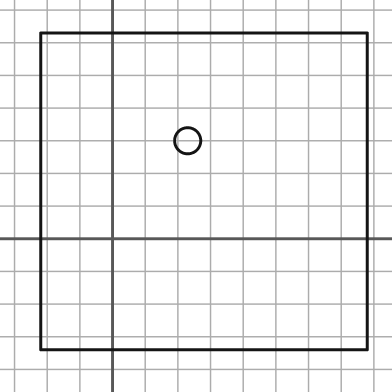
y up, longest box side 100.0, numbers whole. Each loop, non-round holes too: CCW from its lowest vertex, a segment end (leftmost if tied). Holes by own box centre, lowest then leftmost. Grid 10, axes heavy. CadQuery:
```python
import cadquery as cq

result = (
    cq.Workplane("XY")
    .moveTo(-22.0, -34.0)
    .lineTo(78.0, -34.0)
    .lineTo(78.0, 63.0)
    .lineTo(-22.0, 63.0)
    .close()
    .moveTo(23.0, 30.0)
    .circle(4.0)
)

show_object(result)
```